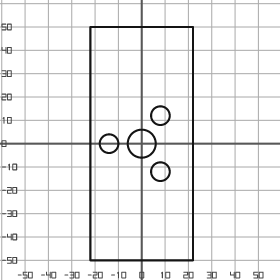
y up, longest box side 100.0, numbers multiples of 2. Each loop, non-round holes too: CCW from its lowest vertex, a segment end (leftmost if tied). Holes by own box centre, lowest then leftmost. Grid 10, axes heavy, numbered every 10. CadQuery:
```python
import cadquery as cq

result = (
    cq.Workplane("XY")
    .moveTo(-22.0, -50.0)
    .lineTo(22.0, -50.0)
    .lineTo(22.0, 50.0)
    .lineTo(-22.0, 50.0)
    .close()
    .moveTo(8.0, -12.0)
    .circle(4.0)
    .moveTo(-14.0, 0.0)
    .circle(4.0)
    .moveTo(0.0, 0.0)
    .circle(6.0)
    .moveTo(8.0, 12.0)
    .circle(4.0)
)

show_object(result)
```